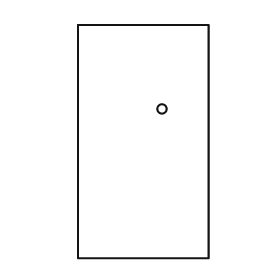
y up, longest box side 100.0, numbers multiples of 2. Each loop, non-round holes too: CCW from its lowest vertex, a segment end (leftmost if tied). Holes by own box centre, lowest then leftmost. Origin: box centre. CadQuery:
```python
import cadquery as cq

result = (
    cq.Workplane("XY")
    .moveTo(-28.0, -50.0)
    .lineTo(28.0, -50.0)
    .lineTo(28.0, 50.0)
    .lineTo(-28.0, 50.0)
    .close()
    .moveTo(8.0, 14.0)
    .circle(2.0)
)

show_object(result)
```